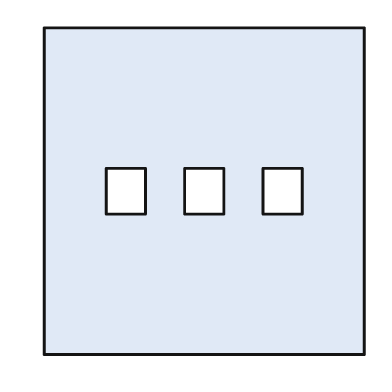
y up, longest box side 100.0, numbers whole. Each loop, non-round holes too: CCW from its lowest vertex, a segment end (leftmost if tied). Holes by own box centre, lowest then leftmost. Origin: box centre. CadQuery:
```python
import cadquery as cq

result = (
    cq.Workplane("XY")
    .moveTo(-49.0, -50.0)
    .lineTo(49.0, -50.0)
    .lineTo(49.0, 50.0)
    .lineTo(-49.0, 50.0)
    .close()
    .moveTo(-30.0, -7.0)
    .lineTo(-18.0, -7.0)
    .lineTo(-18.0, 7.0)
    .lineTo(-30.0, 7.0)
    .close()
    .moveTo(-6.0, -7.0)
    .lineTo(6.0, -7.0)
    .lineTo(6.0, 7.0)
    .lineTo(-6.0, 7.0)
    .close()
    .moveTo(18.0, -7.0)
    .lineTo(30.0, -7.0)
    .lineTo(30.0, 7.0)
    .lineTo(18.0, 7.0)
    .close()
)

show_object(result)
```